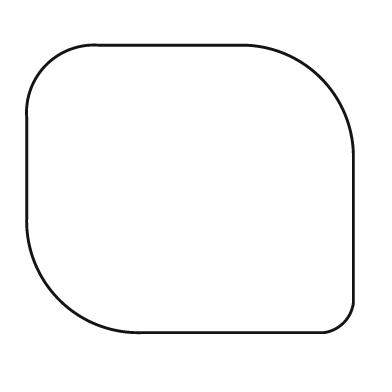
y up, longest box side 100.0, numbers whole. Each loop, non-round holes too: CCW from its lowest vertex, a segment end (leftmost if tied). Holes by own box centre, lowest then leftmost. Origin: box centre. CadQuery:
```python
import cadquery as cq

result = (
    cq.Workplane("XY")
    .moveTo(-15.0, -44.0)
    .lineTo(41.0, -44.0)
    .threePointArc((47.0, -41.0), (50.0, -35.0))
    .lineTo(50.0, 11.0)
    .threePointArc((40.0, 34.0), (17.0, 44.0))
    .lineTo(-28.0, 44.0)
    .threePointArc((-44.0, 38.0), (-50.0, 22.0))
    .lineTo(-50.0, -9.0)
    .threePointArc((-40.0, -34.0), (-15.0, -44.0))
    .close()
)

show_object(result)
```